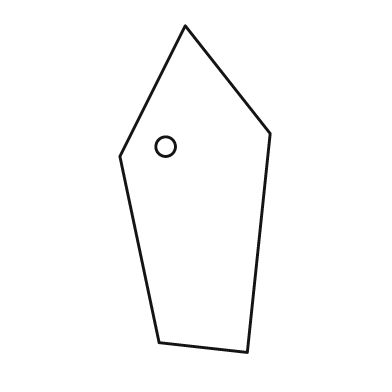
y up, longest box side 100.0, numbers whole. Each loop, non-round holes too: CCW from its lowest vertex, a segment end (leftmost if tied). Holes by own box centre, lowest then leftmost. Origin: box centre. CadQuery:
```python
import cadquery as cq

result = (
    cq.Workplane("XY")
    .moveTo(16.0, -50.0)
    .lineTo(23.0, 17.0)
    .lineTo(-3.0, 50.0)
    .lineTo(-23.0, 10.0)
    .lineTo(-11.0, -47.0)
    .close()
    .moveTo(-9.0, 13.0)
    .circle(3.0)
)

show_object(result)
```